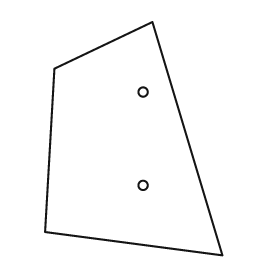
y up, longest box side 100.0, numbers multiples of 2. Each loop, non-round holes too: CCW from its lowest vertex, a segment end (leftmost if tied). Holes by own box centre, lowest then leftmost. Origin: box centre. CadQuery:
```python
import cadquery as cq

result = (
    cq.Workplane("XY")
    .moveTo(38.0, -50.0)
    .lineTo(8.0, 50.0)
    .lineTo(-34.0, 30.0)
    .lineTo(-38.0, -40.0)
    .close()
    .moveTo(4.0, -20.0)
    .circle(2.0)
    .moveTo(4.0, 20.0)
    .circle(2.0)
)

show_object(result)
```